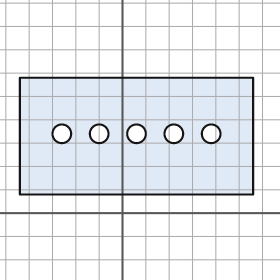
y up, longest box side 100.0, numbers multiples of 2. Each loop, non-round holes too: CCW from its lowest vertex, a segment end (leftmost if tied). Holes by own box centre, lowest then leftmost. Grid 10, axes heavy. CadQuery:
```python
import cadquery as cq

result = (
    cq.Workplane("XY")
    .moveTo(-44.0, 8.0)
    .lineTo(56.0, 8.0)
    .lineTo(56.0, 58.0)
    .lineTo(-44.0, 58.0)
    .close()
    .moveTo(-26.0, 34.0)
    .circle(4.0)
    .moveTo(-10.0, 34.0)
    .circle(4.0)
    .moveTo(6.0, 34.0)
    .circle(4.0)
    .moveTo(22.0, 34.0)
    .circle(4.0)
    .moveTo(38.0, 34.0)
    .circle(4.0)
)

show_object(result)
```